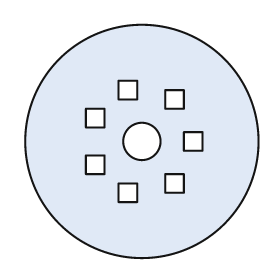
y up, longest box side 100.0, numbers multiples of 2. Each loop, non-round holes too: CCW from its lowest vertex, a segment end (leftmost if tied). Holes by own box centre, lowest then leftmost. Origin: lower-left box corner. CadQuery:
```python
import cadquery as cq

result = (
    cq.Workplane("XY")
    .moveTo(50.0, 50.0)
    .circle(50.0)
    .moveTo(40.0, 24.0)
    .lineTo(48.0, 24.0)
    .lineTo(48.0, 32.0)
    .lineTo(40.0, 32.0)
    .close()
    .moveTo(60.0, 28.0)
    .lineTo(68.0, 28.0)
    .lineTo(68.0, 36.0)
    .lineTo(60.0, 36.0)
    .close()
    .moveTo(26.0, 36.0)
    .lineTo(34.0, 36.0)
    .lineTo(34.0, 44.0)
    .lineTo(26.0, 44.0)
    .close()
    .moveTo(50.0, 50.0)
    .circle(8.0)
    .moveTo(68.0, 46.0)
    .lineTo(76.0, 46.0)
    .lineTo(76.0, 54.0)
    .lineTo(68.0, 54.0)
    .close()
    .moveTo(26.0, 56.0)
    .lineTo(34.0, 56.0)
    .lineTo(34.0, 64.0)
    .lineTo(26.0, 64.0)
    .close()
    .moveTo(60.0, 64.0)
    .lineTo(68.0, 64.0)
    .lineTo(68.0, 72.0)
    .lineTo(60.0, 72.0)
    .close()
    .moveTo(40.0, 68.0)
    .lineTo(48.0, 68.0)
    .lineTo(48.0, 76.0)
    .lineTo(40.0, 76.0)
    .close()
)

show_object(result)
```